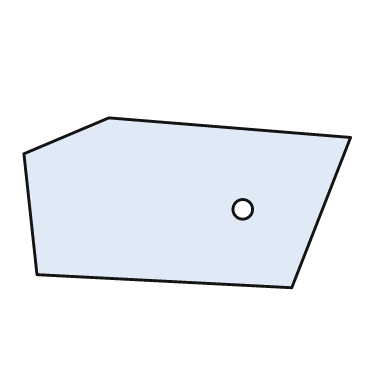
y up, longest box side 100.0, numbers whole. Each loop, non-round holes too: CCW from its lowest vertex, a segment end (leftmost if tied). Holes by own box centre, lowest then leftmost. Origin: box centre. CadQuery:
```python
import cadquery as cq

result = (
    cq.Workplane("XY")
    .moveTo(32.0, -26.0)
    .lineTo(50.0, 20.0)
    .lineTo(-24.0, 26.0)
    .lineTo(-50.0, 15.0)
    .lineTo(-46.0, -22.0)
    .close()
    .moveTo(17.0, -2.0)
    .circle(3.0)
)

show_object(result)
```